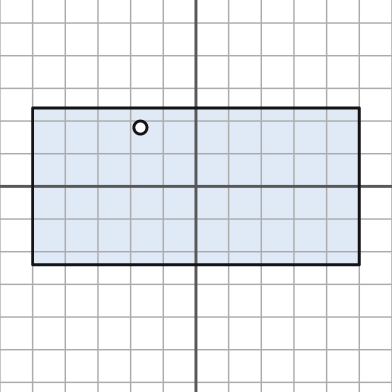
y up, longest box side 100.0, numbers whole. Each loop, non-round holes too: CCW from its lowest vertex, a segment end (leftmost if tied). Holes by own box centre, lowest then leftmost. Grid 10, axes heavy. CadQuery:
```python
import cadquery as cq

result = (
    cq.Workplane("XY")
    .moveTo(-50.0, -24.0)
    .lineTo(50.0, -24.0)
    .lineTo(50.0, 24.0)
    .lineTo(-50.0, 24.0)
    .close()
    .moveTo(-17.0, 18.0)
    .circle(2.0)
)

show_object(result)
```